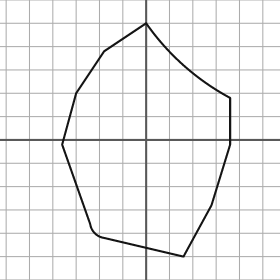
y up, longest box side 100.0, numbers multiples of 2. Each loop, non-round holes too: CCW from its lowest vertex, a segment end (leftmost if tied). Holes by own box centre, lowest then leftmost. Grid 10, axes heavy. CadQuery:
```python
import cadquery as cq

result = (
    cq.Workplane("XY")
    .moveTo(16.0, -50.0)
    .lineTo(28.0, -28.0)
    .lineTo(36.0, -2.0)
    .lineTo(36.0, 18.0)
    .threePointArc((16.0, 32.0), (0.0, 50.0))
    .lineTo(-18.0, 38.0)
    .lineTo(-30.0, 20.0)
    .lineTo(-36.0, -2.0)
    .lineTo(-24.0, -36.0)
    .threePointArc((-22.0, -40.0), (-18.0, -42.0))
    .close()
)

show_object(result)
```